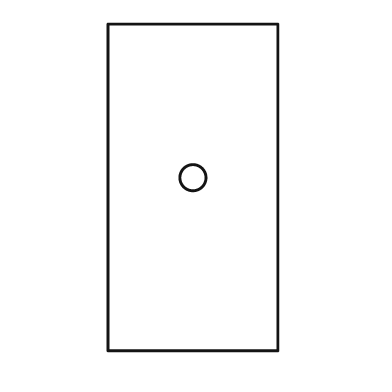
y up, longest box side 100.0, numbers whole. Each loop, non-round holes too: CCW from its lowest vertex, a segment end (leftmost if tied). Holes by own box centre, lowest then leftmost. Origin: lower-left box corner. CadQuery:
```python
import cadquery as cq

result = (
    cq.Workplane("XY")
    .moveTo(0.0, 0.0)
    .lineTo(52.0, 0.0)
    .lineTo(52.0, 100.0)
    .lineTo(0.0, 100.0)
    .close()
    .moveTo(26.0, 53.0)
    .circle(4.0)
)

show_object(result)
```